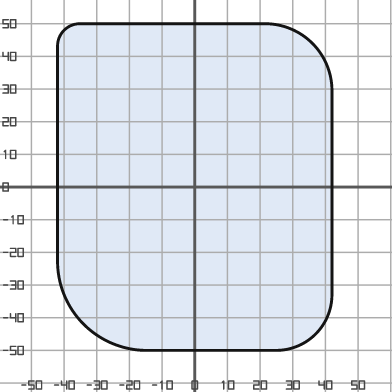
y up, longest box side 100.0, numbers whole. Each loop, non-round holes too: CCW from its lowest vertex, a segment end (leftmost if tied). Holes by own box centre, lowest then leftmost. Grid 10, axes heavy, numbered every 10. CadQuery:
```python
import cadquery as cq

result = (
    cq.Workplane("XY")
    .moveTo(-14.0, -50.0)
    .lineTo(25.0, -50.0)
    .threePointArc((37.0, -45.0), (42.0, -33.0))
    .lineTo(42.0, 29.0)
    .threePointArc((36.0, 44.0), (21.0, 50.0))
    .lineTo(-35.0, 50.0)
    .threePointArc((-40.0, 48.0), (-42.0, 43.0))
    .lineTo(-42.0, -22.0)
    .threePointArc((-34.0, -42.0), (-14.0, -50.0))
    .close()
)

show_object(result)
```